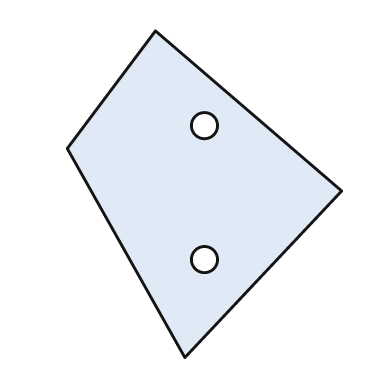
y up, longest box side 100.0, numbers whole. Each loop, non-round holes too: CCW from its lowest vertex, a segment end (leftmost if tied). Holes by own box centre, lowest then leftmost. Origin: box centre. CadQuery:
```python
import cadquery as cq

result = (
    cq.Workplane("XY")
    .moveTo(-6.0, -50.0)
    .lineTo(42.0, 1.0)
    .lineTo(-15.0, 50.0)
    .lineTo(-42.0, 14.0)
    .close()
    .moveTo(0.0, -20.0)
    .circle(4.0)
    .moveTo(0.0, 21.0)
    .circle(4.0)
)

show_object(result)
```